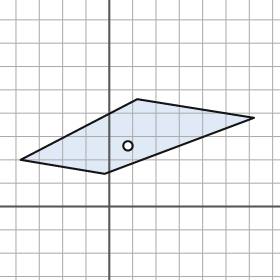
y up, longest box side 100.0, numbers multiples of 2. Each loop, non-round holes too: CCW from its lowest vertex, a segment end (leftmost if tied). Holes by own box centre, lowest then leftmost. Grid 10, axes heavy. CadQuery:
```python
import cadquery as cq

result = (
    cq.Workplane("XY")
    .moveTo(-2.0, 14.0)
    .lineTo(62.0, 38.0)
    .lineTo(12.0, 46.0)
    .lineTo(-38.0, 20.0)
    .close()
    .moveTo(8.0, 26.0)
    .circle(2.0)
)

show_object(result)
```